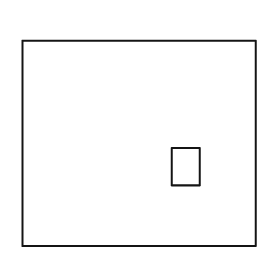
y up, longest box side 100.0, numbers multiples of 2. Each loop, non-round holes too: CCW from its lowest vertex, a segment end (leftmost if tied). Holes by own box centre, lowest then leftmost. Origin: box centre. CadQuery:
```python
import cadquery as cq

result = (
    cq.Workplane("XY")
    .moveTo(-50.0, -44.0)
    .lineTo(50.0, -44.0)
    .lineTo(50.0, 44.0)
    .lineTo(-50.0, 44.0)
    .close()
    .moveTo(14.0, -18.0)
    .lineTo(26.0, -18.0)
    .lineTo(26.0, -2.0)
    .lineTo(14.0, -2.0)
    .close()
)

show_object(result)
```